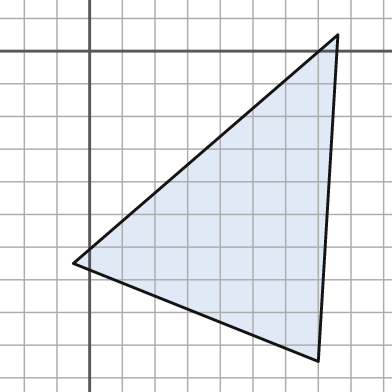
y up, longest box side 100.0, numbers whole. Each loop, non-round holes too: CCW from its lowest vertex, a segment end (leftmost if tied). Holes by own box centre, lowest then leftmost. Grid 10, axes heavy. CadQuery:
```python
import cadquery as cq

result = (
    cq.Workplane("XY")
    .moveTo(70.0, -95.0)
    .lineTo(76.0, 5.0)
    .lineTo(-5.0, -65.0)
    .close()
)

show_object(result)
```